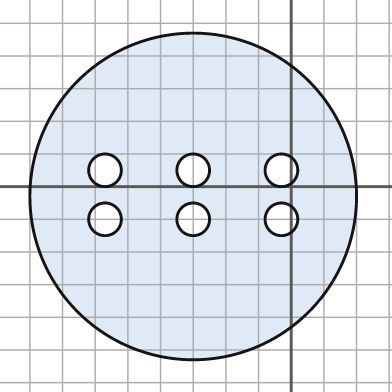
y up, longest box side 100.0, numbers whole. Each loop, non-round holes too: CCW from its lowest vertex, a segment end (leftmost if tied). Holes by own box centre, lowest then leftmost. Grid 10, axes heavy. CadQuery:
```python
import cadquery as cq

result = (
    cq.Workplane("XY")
    .moveTo(-30.0, -3.0)
    .circle(50.0)
    .moveTo(-57.0, -10.0)
    .circle(5.0)
    .moveTo(-30.0, -10.0)
    .circle(5.0)
    .moveTo(-3.0, -10.0)
    .circle(5.0)
    .moveTo(-57.0, 5.0)
    .circle(5.0)
    .moveTo(-30.0, 5.0)
    .circle(5.0)
    .moveTo(-3.0, 5.0)
    .circle(5.0)
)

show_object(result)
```